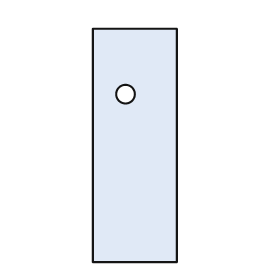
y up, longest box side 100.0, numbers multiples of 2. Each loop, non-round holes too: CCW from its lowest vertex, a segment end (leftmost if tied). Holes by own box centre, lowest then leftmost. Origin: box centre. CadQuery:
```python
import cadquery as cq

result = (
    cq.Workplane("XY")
    .moveTo(-18.0, -50.0)
    .lineTo(18.0, -50.0)
    .lineTo(18.0, 50.0)
    .lineTo(-18.0, 50.0)
    .close()
    .moveTo(-4.0, 22.0)
    .circle(4.0)
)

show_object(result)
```